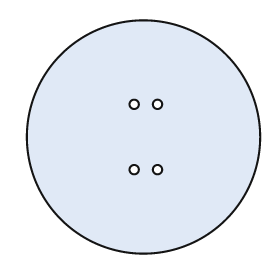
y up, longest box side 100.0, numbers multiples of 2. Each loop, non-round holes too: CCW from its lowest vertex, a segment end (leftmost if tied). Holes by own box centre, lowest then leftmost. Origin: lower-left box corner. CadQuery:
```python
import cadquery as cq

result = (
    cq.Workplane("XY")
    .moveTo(50.0, 50.0)
    .circle(50.0)
    .moveTo(46.0, 36.0)
    .circle(2.0)
    .moveTo(56.0, 36.0)
    .circle(2.0)
    .moveTo(46.0, 64.0)
    .circle(2.0)
    .moveTo(56.0, 64.0)
    .circle(2.0)
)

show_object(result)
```